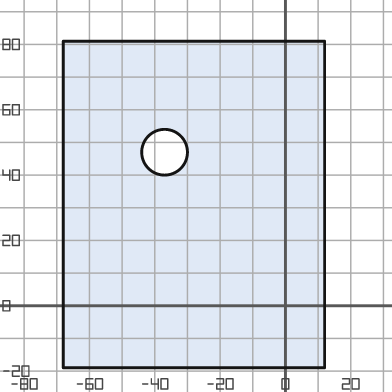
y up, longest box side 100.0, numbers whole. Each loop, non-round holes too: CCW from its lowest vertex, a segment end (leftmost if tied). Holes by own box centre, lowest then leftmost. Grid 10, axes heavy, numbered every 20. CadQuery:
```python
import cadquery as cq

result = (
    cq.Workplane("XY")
    .moveTo(-68.0, -19.0)
    .lineTo(12.0, -19.0)
    .lineTo(12.0, 81.0)
    .lineTo(-68.0, 81.0)
    .close()
    .moveTo(-37.0, 47.0)
    .circle(7.0)
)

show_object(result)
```